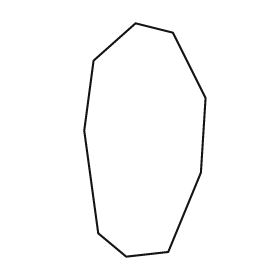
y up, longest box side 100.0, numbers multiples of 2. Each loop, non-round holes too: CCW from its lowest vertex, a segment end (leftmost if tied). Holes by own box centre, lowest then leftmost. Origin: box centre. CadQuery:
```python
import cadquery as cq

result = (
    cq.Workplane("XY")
    .moveTo(-8.0, -50.0)
    .lineTo(10.0, -48.0)
    .lineTo(24.0, -14.0)
    .lineTo(26.0, 18.0)
    .lineTo(12.0, 46.0)
    .lineTo(-4.0, 50.0)
    .lineTo(-22.0, 34.0)
    .lineTo(-26.0, 4.0)
    .lineTo(-20.0, -40.0)
    .close()
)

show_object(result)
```